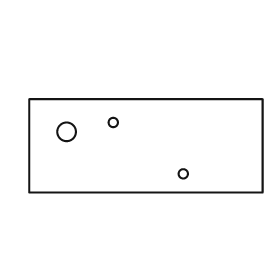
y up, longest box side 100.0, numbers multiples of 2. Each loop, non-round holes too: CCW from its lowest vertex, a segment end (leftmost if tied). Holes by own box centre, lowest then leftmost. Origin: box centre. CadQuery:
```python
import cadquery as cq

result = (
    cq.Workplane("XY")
    .moveTo(-50.0, -20.0)
    .lineTo(50.0, -20.0)
    .lineTo(50.0, 20.0)
    .lineTo(-50.0, 20.0)
    .close()
    .moveTo(16.0, -12.0)
    .circle(2.0)
    .moveTo(-34.0, 6.0)
    .circle(4.0)
    .moveTo(-14.0, 10.0)
    .circle(2.0)
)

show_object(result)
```